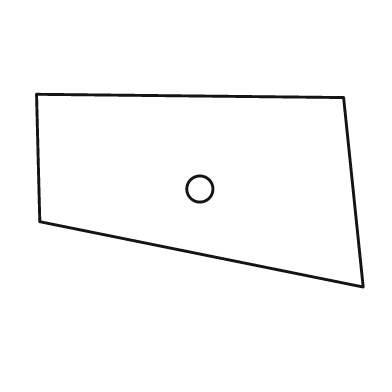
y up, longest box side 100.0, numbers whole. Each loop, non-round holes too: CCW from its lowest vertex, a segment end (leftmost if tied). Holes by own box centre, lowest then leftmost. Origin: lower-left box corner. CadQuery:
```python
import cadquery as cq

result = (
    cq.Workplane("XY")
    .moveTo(100.0, 0.0)
    .lineTo(94.0, 58.0)
    .lineTo(0.0, 59.0)
    .lineTo(1.0, 20.0)
    .close()
    .moveTo(50.0, 30.0)
    .circle(4.0)
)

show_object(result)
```